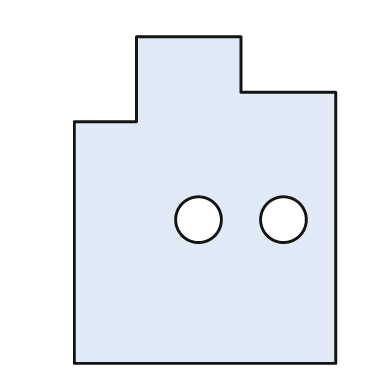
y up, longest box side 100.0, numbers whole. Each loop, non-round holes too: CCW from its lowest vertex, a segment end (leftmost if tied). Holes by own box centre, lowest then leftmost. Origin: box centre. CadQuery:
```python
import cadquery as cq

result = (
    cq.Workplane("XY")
    .moveTo(-40.0, -50.0)
    .lineTo(40.0, -50.0)
    .lineTo(40.0, 33.0)
    .lineTo(11.0, 33.0)
    .lineTo(11.0, 50.0)
    .lineTo(-21.0, 50.0)
    .lineTo(-21.0, 24.0)
    .lineTo(-40.0, 24.0)
    .close()
    .moveTo(-2.0, -6.0)
    .circle(7.0)
    .moveTo(24.0, -6.0)
    .circle(7.0)
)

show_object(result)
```